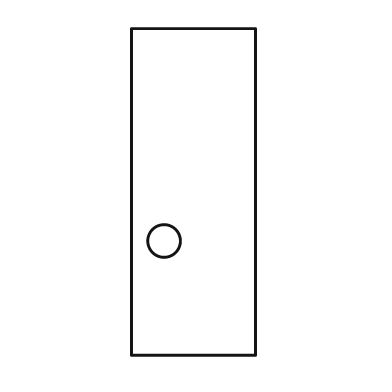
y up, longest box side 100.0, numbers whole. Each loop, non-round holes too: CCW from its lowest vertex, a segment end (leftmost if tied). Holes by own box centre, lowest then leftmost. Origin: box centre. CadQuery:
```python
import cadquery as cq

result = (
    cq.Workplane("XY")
    .moveTo(-19.0, -50.0)
    .lineTo(19.0, -50.0)
    .lineTo(19.0, 50.0)
    .lineTo(-19.0, 50.0)
    .close()
    .moveTo(-9.0, -15.0)
    .circle(5.0)
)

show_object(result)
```